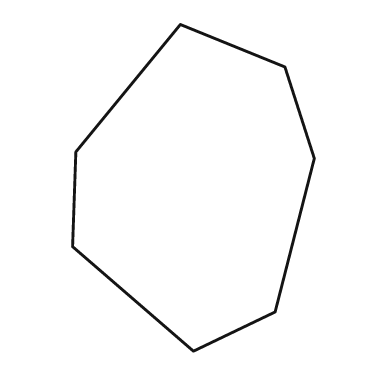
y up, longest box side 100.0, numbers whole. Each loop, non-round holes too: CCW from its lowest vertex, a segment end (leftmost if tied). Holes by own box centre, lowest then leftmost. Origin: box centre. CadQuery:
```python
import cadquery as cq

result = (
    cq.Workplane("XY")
    .moveTo(0.0, -50.0)
    .lineTo(25.0, -38.0)
    .lineTo(37.0, 9.0)
    .lineTo(28.0, 37.0)
    .lineTo(-4.0, 50.0)
    .lineTo(-36.0, 11.0)
    .lineTo(-37.0, -18.0)
    .close()
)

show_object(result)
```